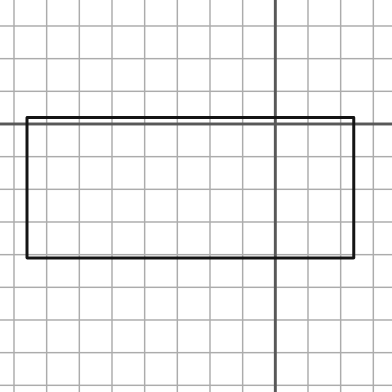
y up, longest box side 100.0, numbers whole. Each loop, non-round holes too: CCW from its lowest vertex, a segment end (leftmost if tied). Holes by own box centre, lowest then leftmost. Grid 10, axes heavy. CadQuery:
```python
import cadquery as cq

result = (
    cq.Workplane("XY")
    .moveTo(-76.0, -41.0)
    .lineTo(24.0, -41.0)
    .lineTo(24.0, 2.0)
    .lineTo(-76.0, 2.0)
    .close()
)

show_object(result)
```